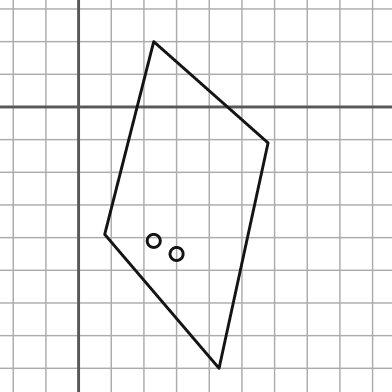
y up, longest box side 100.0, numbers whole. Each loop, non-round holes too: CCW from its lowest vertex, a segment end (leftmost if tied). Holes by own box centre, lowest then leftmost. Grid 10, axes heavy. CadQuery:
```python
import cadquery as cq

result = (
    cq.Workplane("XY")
    .moveTo(43.0, -80.0)
    .lineTo(58.0, -11.0)
    .lineTo(23.0, 20.0)
    .lineTo(8.0, -39.0)
    .close()
    .moveTo(30.0, -45.0)
    .circle(2.0)
    .moveTo(23.0, -41.0)
    .circle(2.0)
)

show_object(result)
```